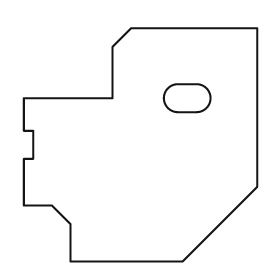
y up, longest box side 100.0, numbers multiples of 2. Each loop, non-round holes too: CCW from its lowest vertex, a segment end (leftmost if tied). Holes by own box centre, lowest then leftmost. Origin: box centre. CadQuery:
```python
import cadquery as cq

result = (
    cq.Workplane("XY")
    .moveTo(-30.0, -50.0)
    .lineTo(18.0, -50.0)
    .lineTo(50.0, -18.0)
    .lineTo(50.0, 50.0)
    .lineTo(-4.0, 50.0)
    .lineTo(-12.0, 42.0)
    .lineTo(-12.0, 20.0)
    .lineTo(-50.0, 20.0)
    .lineTo(-50.0, 6.0)
    .lineTo(-46.0, 6.0)
    .lineTo(-46.0, -6.0)
    .lineTo(-50.0, -6.0)
    .lineTo(-50.0, -26.0)
    .lineTo(-38.0, -26.0)
    .lineTo(-30.0, -34.0)
    .close()
    .moveTo(16.0, 14.0)
    .lineTo(24.0, 14.0)
    .threePointArc((30.0, 20.0), (24.0, 26.0))
    .lineTo(16.0, 26.0)
    .threePointArc((10.0, 20.0), (16.0, 14.0))
    .close()
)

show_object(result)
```